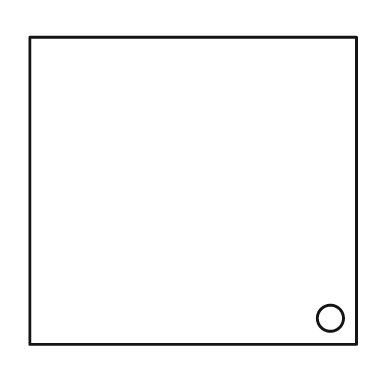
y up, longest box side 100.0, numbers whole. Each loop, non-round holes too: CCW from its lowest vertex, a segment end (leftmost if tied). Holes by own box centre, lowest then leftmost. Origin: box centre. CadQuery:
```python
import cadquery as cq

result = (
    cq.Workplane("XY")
    .moveTo(-50.0, -47.0)
    .lineTo(50.0, -47.0)
    .lineTo(50.0, 47.0)
    .lineTo(-50.0, 47.0)
    .close()
    .moveTo(42.0, -39.0)
    .circle(4.0)
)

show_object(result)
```